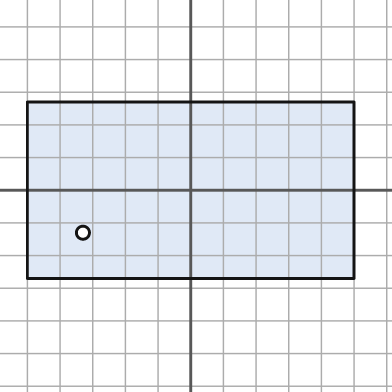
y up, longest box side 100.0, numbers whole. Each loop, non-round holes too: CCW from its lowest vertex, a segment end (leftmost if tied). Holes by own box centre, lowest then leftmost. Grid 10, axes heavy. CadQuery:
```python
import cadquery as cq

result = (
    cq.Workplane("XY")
    .moveTo(-50.0, -27.0)
    .lineTo(50.0, -27.0)
    .lineTo(50.0, 27.0)
    .lineTo(-50.0, 27.0)
    .close()
    .moveTo(-33.0, -13.0)
    .circle(2.0)
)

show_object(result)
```